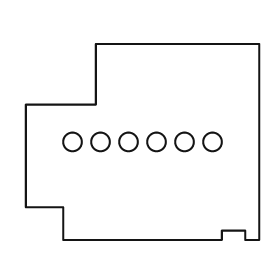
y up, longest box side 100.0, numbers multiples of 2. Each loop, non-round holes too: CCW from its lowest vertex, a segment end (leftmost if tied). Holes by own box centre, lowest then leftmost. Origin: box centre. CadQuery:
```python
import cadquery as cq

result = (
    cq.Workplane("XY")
    .moveTo(-34.0, -42.0)
    .lineTo(34.0, -42.0)
    .lineTo(34.0, -38.0)
    .lineTo(44.0, -38.0)
    .lineTo(44.0, -42.0)
    .lineTo(50.0, -42.0)
    .lineTo(50.0, 42.0)
    .lineTo(-20.0, 42.0)
    .lineTo(-20.0, 16.0)
    .lineTo(-50.0, 16.0)
    .lineTo(-50.0, -28.0)
    .lineTo(-34.0, -28.0)
    .close()
    .moveTo(-30.0, 0.0)
    .circle(4.0)
    .moveTo(-18.0, 0.0)
    .circle(4.0)
    .moveTo(-6.0, 0.0)
    .circle(4.0)
    .moveTo(6.0, 0.0)
    .circle(4.0)
    .moveTo(18.0, 0.0)
    .circle(4.0)
    .moveTo(30.0, 0.0)
    .circle(4.0)
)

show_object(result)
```